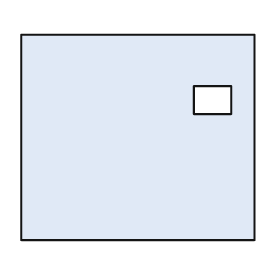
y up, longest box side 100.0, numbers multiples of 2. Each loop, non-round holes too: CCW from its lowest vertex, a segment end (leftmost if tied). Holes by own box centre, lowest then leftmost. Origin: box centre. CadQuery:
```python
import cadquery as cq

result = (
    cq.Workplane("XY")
    .moveTo(-50.0, -44.0)
    .lineTo(50.0, -44.0)
    .lineTo(50.0, 44.0)
    .lineTo(-50.0, 44.0)
    .close()
    .moveTo(24.0, 10.0)
    .lineTo(40.0, 10.0)
    .lineTo(40.0, 22.0)
    .lineTo(24.0, 22.0)
    .close()
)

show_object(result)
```